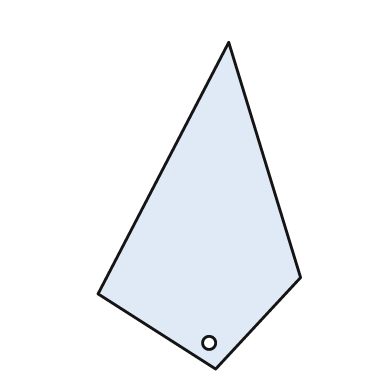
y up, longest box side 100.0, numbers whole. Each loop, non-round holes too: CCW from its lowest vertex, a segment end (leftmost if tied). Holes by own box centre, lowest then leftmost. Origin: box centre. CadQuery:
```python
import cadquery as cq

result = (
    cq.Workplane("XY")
    .moveTo(5.0, -50.0)
    .lineTo(31.0, -22.0)
    .lineTo(9.0, 50.0)
    .lineTo(-31.0, -27.0)
    .close()
    .moveTo(3.0, -42.0)
    .circle(2.0)
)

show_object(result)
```